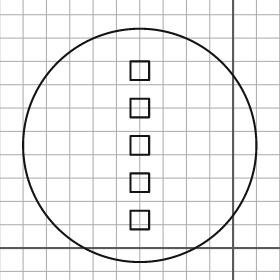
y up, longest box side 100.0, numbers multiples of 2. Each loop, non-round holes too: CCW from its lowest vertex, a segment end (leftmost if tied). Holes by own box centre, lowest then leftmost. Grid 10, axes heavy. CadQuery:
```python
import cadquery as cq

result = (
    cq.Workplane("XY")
    .moveTo(-40.0, 44.0)
    .circle(50.0)
    .moveTo(-44.0, 8.0)
    .lineTo(-36.0, 8.0)
    .lineTo(-36.0, 16.0)
    .lineTo(-44.0, 16.0)
    .close()
    .moveTo(-44.0, 24.0)
    .lineTo(-36.0, 24.0)
    .lineTo(-36.0, 32.0)
    .lineTo(-44.0, 32.0)
    .close()
    .moveTo(-44.0, 40.0)
    .lineTo(-36.0, 40.0)
    .lineTo(-36.0, 48.0)
    .lineTo(-44.0, 48.0)
    .close()
    .moveTo(-44.0, 56.0)
    .lineTo(-36.0, 56.0)
    .lineTo(-36.0, 64.0)
    .lineTo(-44.0, 64.0)
    .close()
    .moveTo(-44.0, 72.0)
    .lineTo(-36.0, 72.0)
    .lineTo(-36.0, 80.0)
    .lineTo(-44.0, 80.0)
    .close()
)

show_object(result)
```